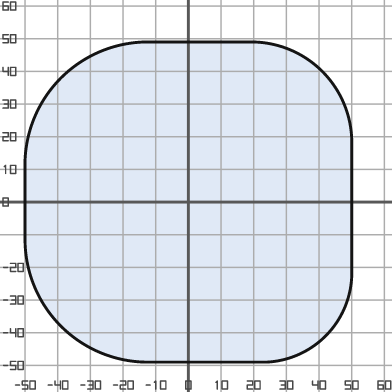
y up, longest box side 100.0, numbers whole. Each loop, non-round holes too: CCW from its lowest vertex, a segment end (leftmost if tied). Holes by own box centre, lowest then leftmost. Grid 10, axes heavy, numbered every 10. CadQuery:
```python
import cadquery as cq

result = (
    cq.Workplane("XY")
    .moveTo(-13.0, -49.0)
    .lineTo(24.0, -49.0)
    .threePointArc((42.0, -41.0), (50.0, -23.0))
    .lineTo(50.0, 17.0)
    .threePointArc((41.0, 40.0), (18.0, 49.0))
    .lineTo(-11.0, 49.0)
    .threePointArc((-39.0, 38.0), (-50.0, 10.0))
    .lineTo(-50.0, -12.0)
    .threePointArc((-39.0, -38.0), (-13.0, -49.0))
    .close()
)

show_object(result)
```